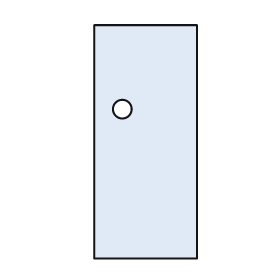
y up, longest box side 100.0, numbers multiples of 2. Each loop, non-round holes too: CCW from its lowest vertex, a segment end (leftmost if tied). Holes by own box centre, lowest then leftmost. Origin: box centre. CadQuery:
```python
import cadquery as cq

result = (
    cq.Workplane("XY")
    .moveTo(-22.0, -50.0)
    .lineTo(22.0, -50.0)
    .lineTo(22.0, 50.0)
    .lineTo(-22.0, 50.0)
    .close()
    .moveTo(-10.0, 14.0)
    .circle(4.0)
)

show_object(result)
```